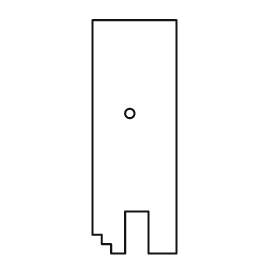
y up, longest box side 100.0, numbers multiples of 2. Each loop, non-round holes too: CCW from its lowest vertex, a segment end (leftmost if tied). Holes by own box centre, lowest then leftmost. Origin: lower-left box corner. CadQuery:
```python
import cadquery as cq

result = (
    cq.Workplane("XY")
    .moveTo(8.0, 0.0)
    .lineTo(14.0, 0.0)
    .lineTo(14.0, 18.0)
    .lineTo(24.0, 18.0)
    .lineTo(24.0, 0.0)
    .lineTo(36.0, 0.0)
    .lineTo(36.0, 100.0)
    .lineTo(0.0, 100.0)
    .lineTo(0.0, 8.0)
    .lineTo(4.0, 8.0)
    .lineTo(4.0, 4.0)
    .lineTo(8.0, 4.0)
    .close()
    .moveTo(16.0, 60.0)
    .circle(2.0)
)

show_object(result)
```